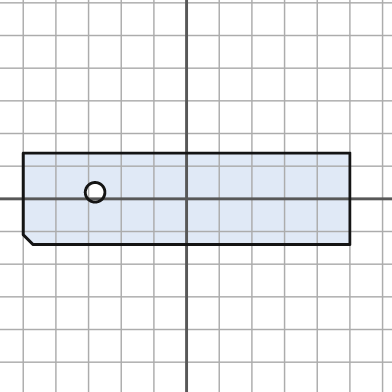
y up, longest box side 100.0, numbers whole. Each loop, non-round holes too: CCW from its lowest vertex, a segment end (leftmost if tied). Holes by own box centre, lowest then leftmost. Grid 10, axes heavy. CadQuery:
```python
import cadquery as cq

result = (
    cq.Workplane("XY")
    .moveTo(-47.0, -14.0)
    .lineTo(50.0, -14.0)
    .lineTo(50.0, 14.0)
    .lineTo(-50.0, 14.0)
    .lineTo(-50.0, -11.0)
    .close()
    .moveTo(-28.0, 2.0)
    .circle(3.0)
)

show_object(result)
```